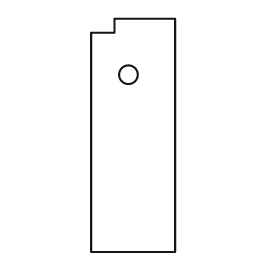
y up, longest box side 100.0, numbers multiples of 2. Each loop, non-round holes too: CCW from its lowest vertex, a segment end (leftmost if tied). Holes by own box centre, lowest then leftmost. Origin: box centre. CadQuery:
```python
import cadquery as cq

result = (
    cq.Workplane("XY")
    .moveTo(-18.0, -50.0)
    .lineTo(18.0, -50.0)
    .lineTo(18.0, 50.0)
    .lineTo(-8.0, 50.0)
    .lineTo(-8.0, 44.0)
    .lineTo(-18.0, 44.0)
    .close()
    .moveTo(-2.0, 26.0)
    .circle(4.0)
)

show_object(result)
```